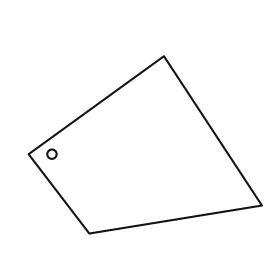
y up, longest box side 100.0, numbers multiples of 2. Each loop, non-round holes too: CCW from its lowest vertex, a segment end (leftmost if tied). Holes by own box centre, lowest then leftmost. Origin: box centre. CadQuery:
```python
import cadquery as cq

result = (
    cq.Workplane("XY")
    .moveTo(-24.0, -38.0)
    .lineTo(50.0, -26.0)
    .lineTo(8.0, 38.0)
    .lineTo(-50.0, -4.0)
    .close()
    .moveTo(-40.0, -4.0)
    .circle(2.0)
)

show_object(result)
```